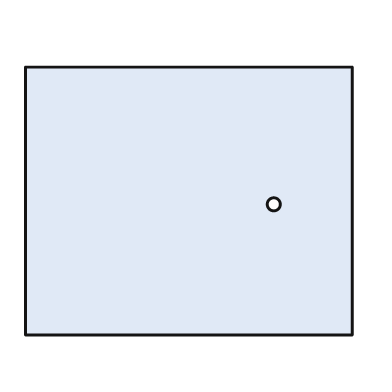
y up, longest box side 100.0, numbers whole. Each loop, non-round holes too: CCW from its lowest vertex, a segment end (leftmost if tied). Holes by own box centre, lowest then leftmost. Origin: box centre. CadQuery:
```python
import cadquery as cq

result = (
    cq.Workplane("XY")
    .moveTo(-50.0, -41.0)
    .lineTo(50.0, -41.0)
    .lineTo(50.0, 41.0)
    .lineTo(-50.0, 41.0)
    .close()
    .moveTo(26.0, -1.0)
    .circle(2.0)
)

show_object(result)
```